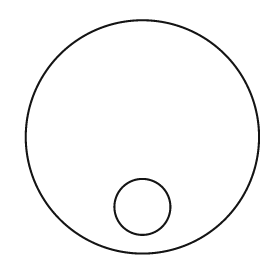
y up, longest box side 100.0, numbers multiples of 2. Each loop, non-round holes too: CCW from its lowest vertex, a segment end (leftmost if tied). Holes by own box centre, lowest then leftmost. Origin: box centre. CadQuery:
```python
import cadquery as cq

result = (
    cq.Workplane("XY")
    .moveTo(0.0, 0.0)
    .circle(50.0)
    .moveTo(0.0, -30.0)
    .circle(12.0)
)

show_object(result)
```